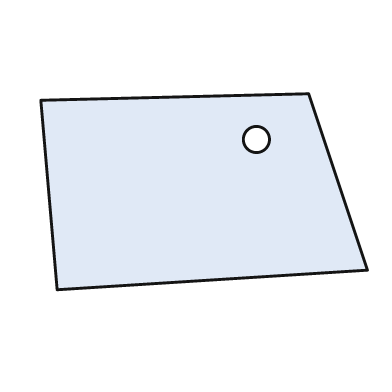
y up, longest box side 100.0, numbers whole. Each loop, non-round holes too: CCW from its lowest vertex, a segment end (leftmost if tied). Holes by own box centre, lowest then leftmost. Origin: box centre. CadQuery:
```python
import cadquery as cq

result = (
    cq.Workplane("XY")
    .moveTo(-45.0, -30.0)
    .lineTo(50.0, -24.0)
    .lineTo(32.0, 30.0)
    .lineTo(-50.0, 28.0)
    .close()
    .moveTo(16.0, 16.0)
    .circle(4.0)
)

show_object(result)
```